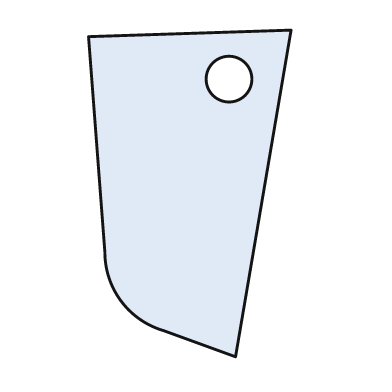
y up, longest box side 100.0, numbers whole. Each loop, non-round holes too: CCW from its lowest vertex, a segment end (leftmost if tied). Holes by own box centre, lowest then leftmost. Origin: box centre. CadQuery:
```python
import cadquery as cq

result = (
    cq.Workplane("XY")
    .moveTo(14.0, -50.0)
    .lineTo(31.0, 50.0)
    .lineTo(-31.0, 48.0)
    .lineTo(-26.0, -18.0)
    .threePointArc((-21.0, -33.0), (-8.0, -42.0))
    .close()
    .moveTo(12.0, 35.0)
    .circle(7.0)
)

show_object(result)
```